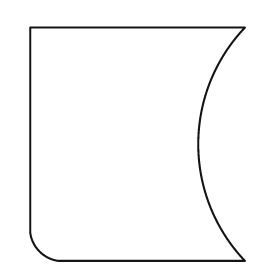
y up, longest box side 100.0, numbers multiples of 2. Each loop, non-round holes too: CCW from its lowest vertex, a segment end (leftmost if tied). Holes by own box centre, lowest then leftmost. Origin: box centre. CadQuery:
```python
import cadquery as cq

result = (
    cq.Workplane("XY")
    .moveTo(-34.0, -50.0)
    .lineTo(46.0, -50.0)
    .threePointArc((26.0, 0.0), (46.0, 50.0))
    .lineTo(-46.0, 50.0)
    .lineTo(-46.0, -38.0)
    .threePointArc((-42.0, -46.0), (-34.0, -50.0))
    .close()
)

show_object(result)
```